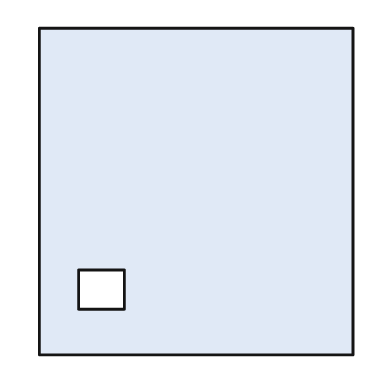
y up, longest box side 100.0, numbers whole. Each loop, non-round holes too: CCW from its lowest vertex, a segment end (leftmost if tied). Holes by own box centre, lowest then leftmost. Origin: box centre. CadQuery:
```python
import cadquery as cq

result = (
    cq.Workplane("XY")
    .moveTo(-48.0, -50.0)
    .lineTo(48.0, -50.0)
    .lineTo(48.0, 50.0)
    .lineTo(-48.0, 50.0)
    .close()
    .moveTo(-36.0, -36.0)
    .lineTo(-22.0, -36.0)
    .lineTo(-22.0, -24.0)
    .lineTo(-36.0, -24.0)
    .close()
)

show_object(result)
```